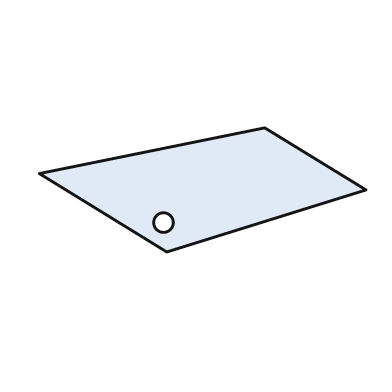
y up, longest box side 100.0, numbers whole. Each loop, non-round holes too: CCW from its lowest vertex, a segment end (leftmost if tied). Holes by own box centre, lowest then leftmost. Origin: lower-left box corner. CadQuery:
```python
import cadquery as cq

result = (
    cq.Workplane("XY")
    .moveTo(39.0, 0.0)
    .lineTo(100.0, 19.0)
    .lineTo(69.0, 38.0)
    .lineTo(0.0, 24.0)
    .close()
    .moveTo(38.0, 9.0)
    .circle(3.0)
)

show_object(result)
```